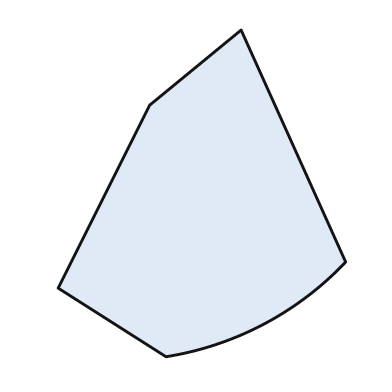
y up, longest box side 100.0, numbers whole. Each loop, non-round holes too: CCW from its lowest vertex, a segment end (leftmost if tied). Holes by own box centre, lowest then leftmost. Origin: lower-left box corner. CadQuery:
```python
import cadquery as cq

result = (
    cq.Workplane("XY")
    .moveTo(33.0, 0.0)
    .threePointArc((63.0, 10.0), (88.0, 29.0))
    .lineTo(56.0, 100.0)
    .lineTo(28.0, 77.0)
    .lineTo(0.0, 21.0)
    .close()
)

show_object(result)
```